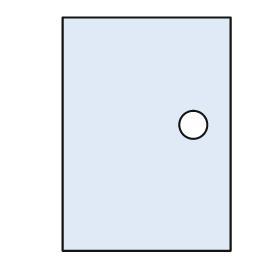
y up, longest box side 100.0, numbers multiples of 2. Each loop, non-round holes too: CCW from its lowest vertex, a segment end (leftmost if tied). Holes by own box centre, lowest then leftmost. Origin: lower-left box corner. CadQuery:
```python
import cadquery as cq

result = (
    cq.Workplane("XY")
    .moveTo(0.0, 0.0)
    .lineTo(72.0, 0.0)
    .lineTo(72.0, 100.0)
    .lineTo(0.0, 100.0)
    .close()
    .moveTo(56.0, 54.0)
    .circle(6.0)
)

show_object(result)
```